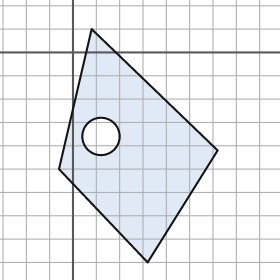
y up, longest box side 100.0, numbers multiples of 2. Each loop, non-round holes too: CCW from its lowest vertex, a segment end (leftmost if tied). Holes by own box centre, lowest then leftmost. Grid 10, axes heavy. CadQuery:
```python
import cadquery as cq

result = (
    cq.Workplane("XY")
    .moveTo(32.0, -90.0)
    .lineTo(62.0, -42.0)
    .lineTo(8.0, 10.0)
    .lineTo(-6.0, -50.0)
    .close()
    .moveTo(12.0, -36.0)
    .circle(8.0)
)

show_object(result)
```